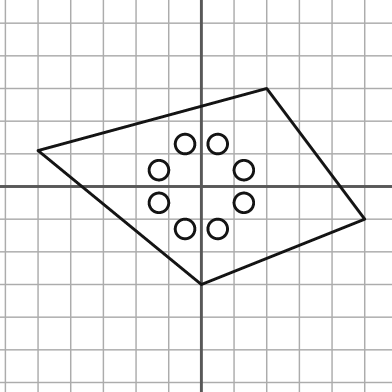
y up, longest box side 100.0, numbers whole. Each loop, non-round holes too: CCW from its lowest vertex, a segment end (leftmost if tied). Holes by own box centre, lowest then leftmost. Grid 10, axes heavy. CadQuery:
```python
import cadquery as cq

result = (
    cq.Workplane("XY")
    .moveTo(0.0, -30.0)
    .lineTo(50.0, -10.0)
    .lineTo(20.0, 30.0)
    .lineTo(-50.0, 11.0)
    .close()
    .moveTo(-5.0, -13.0)
    .circle(3.0)
    .moveTo(5.0, -13.0)
    .circle(3.0)
    .moveTo(-13.0, -5.0)
    .circle(3.0)
    .moveTo(13.0, -5.0)
    .circle(3.0)
    .moveTo(-13.0, 5.0)
    .circle(3.0)
    .moveTo(13.0, 5.0)
    .circle(3.0)
    .moveTo(-5.0, 13.0)
    .circle(3.0)
    .moveTo(5.0, 13.0)
    .circle(3.0)
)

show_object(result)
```